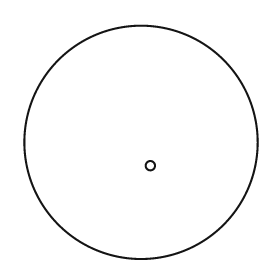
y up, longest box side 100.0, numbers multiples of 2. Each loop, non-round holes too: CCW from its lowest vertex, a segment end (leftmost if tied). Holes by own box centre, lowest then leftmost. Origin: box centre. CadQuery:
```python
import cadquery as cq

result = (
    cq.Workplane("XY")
    .moveTo(0.0, 0.0)
    .circle(50.0)
    .moveTo(4.0, -10.0)
    .circle(2.0)
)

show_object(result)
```